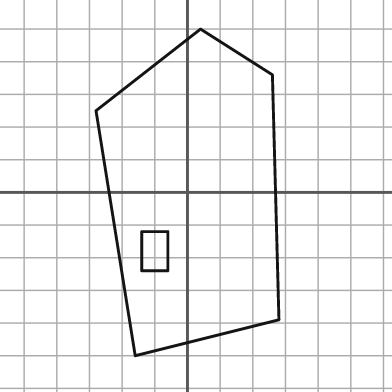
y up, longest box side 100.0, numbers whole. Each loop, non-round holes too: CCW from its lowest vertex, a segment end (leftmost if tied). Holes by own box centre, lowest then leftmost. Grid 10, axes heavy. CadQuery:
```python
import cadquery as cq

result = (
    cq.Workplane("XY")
    .moveTo(-16.0, -50.0)
    .lineTo(28.0, -39.0)
    .lineTo(26.0, 36.0)
    .lineTo(4.0, 50.0)
    .lineTo(-28.0, 25.0)
    .close()
    .moveTo(-14.0, -24.0)
    .lineTo(-6.0, -24.0)
    .lineTo(-6.0, -12.0)
    .lineTo(-14.0, -12.0)
    .close()
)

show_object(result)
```